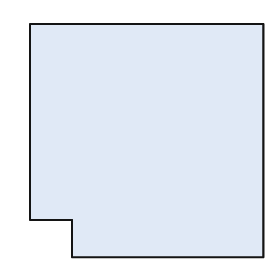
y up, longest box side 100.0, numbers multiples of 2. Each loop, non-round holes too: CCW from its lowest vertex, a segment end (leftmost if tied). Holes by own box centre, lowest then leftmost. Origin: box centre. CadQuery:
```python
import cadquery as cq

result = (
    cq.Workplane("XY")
    .moveTo(-32.0, -50.0)
    .lineTo(50.0, -50.0)
    .lineTo(50.0, 50.0)
    .lineTo(-50.0, 50.0)
    .lineTo(-50.0, -34.0)
    .lineTo(-32.0, -34.0)
    .close()
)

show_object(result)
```